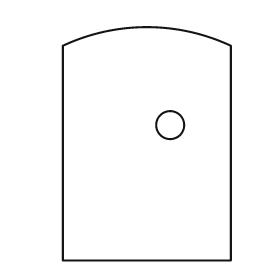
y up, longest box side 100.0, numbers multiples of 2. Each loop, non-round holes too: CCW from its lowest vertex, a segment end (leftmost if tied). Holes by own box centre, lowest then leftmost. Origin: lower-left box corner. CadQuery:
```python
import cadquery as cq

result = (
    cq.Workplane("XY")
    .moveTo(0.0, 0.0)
    .lineTo(72.0, 0.0)
    .lineTo(72.0, 92.0)
    .threePointArc((36.0, 100.0), (0.0, 92.0))
    .close()
    .moveTo(46.0, 58.0)
    .circle(6.0)
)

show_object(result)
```